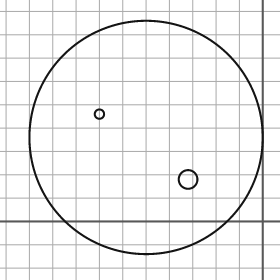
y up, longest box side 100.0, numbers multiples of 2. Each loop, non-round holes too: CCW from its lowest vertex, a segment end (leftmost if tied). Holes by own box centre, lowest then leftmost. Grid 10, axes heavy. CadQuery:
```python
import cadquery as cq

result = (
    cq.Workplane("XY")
    .moveTo(-50.0, 36.0)
    .circle(50.0)
    .moveTo(-32.0, 18.0)
    .circle(4.0)
    .moveTo(-70.0, 46.0)
    .circle(2.0)
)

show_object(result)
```